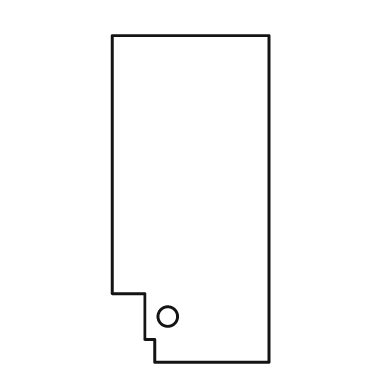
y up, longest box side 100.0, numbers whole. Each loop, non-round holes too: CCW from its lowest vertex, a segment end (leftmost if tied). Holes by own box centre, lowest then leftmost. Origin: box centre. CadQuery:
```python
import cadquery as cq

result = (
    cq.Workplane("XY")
    .moveTo(-11.0, -50.0)
    .lineTo(24.0, -50.0)
    .lineTo(24.0, 50.0)
    .lineTo(-24.0, 50.0)
    .lineTo(-24.0, -29.0)
    .lineTo(-14.0, -29.0)
    .lineTo(-14.0, -43.0)
    .lineTo(-11.0, -43.0)
    .close()
    .moveTo(-7.0, -36.0)
    .circle(3.0)
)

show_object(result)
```